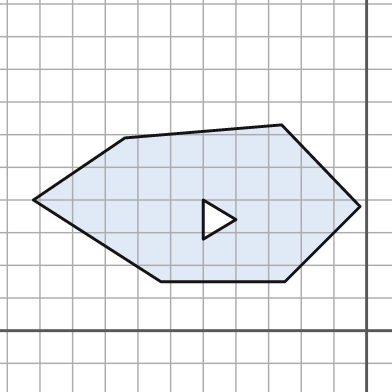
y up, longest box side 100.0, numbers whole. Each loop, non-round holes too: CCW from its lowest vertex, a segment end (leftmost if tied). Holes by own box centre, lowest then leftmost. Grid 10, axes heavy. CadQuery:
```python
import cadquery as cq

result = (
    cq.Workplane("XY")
    .moveTo(-63.0, 15.0)
    .lineTo(-25.0, 15.0)
    .lineTo(-2.0, 38.0)
    .lineTo(-26.0, 63.0)
    .lineTo(-74.0, 59.0)
    .lineTo(-102.0, 40.0)
    .close()
    .moveTo(-50.0, 28.0)
    .lineTo(-40.0, 34.0)
    .lineTo(-50.0, 40.0)
    .close()
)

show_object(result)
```